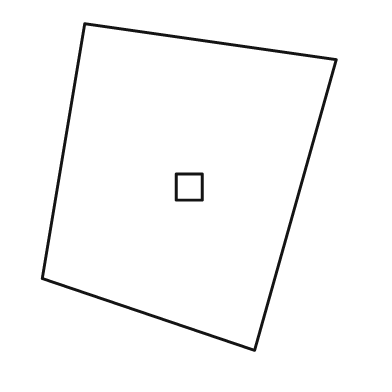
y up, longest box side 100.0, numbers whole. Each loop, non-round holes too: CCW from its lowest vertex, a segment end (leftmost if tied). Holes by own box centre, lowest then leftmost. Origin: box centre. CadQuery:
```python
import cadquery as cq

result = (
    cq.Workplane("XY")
    .moveTo(20.0, -50.0)
    .lineTo(45.0, 39.0)
    .lineTo(-32.0, 50.0)
    .lineTo(-45.0, -28.0)
    .close()
    .moveTo(-4.0, -4.0)
    .lineTo(4.0, -4.0)
    .lineTo(4.0, 4.0)
    .lineTo(-4.0, 4.0)
    .close()
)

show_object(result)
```